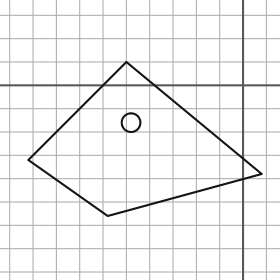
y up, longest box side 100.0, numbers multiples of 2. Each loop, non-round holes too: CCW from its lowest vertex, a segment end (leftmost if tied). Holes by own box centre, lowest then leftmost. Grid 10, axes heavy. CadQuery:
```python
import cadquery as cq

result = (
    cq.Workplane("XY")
    .moveTo(-58.0, -56.0)
    .lineTo(8.0, -38.0)
    .lineTo(-50.0, 10.0)
    .lineTo(-92.0, -32.0)
    .close()
    .moveTo(-48.0, -16.0)
    .circle(4.0)
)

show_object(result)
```